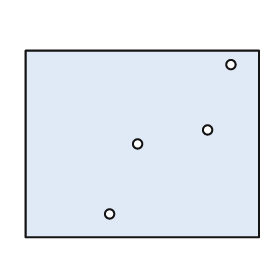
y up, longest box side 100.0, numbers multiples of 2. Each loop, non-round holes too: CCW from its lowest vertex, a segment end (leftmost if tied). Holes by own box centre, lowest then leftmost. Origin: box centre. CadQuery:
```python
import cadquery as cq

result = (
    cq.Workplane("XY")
    .moveTo(-50.0, -40.0)
    .lineTo(50.0, -40.0)
    .lineTo(50.0, 40.0)
    .lineTo(-50.0, 40.0)
    .close()
    .moveTo(-14.0, -30.0)
    .circle(2.0)
    .moveTo(-2.0, 0.0)
    .circle(2.0)
    .moveTo(28.0, 6.0)
    .circle(2.0)
    .moveTo(38.0, 34.0)
    .circle(2.0)
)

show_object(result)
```